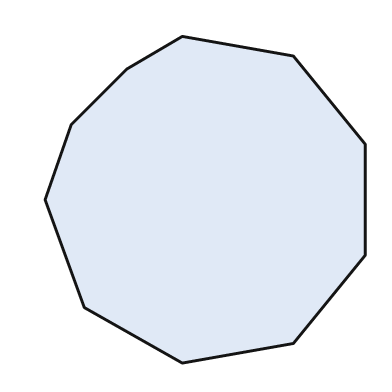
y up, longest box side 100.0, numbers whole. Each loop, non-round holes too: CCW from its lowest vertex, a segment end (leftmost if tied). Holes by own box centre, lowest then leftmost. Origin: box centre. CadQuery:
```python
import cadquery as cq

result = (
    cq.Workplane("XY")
    .moveTo(-7.0, -50.0)
    .lineTo(27.0, -44.0)
    .lineTo(49.0, -17.0)
    .lineTo(49.0, 17.0)
    .lineTo(27.0, 44.0)
    .lineTo(-7.0, 50.0)
    .lineTo(-24.0, 40.0)
    .lineTo(-41.0, 23.0)
    .lineTo(-49.0, 0.0)
    .lineTo(-37.0, -33.0)
    .close()
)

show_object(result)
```